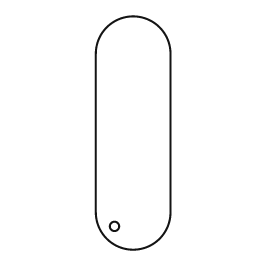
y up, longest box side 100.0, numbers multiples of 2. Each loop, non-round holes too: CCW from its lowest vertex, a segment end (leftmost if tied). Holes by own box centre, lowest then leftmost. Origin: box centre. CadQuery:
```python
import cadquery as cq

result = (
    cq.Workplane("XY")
    .moveTo(-16.0, -34.0)
    .threePointArc((0.0, -50.0), (16.0, -34.0))
    .lineTo(16.0, 34.0)
    .threePointArc((0.0, 50.0), (-16.0, 34.0))
    .close()
    .moveTo(-8.0, -40.0)
    .circle(2.0)
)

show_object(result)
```